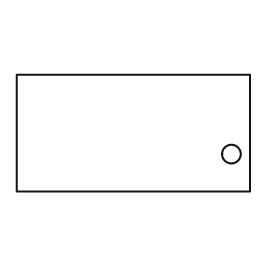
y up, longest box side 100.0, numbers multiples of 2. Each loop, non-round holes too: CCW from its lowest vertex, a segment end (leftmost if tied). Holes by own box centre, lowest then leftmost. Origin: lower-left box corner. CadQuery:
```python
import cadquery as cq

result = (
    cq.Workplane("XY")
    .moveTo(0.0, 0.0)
    .lineTo(100.0, 0.0)
    .lineTo(100.0, 50.0)
    .lineTo(0.0, 50.0)
    .close()
    .moveTo(92.0, 16.0)
    .circle(4.0)
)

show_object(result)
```